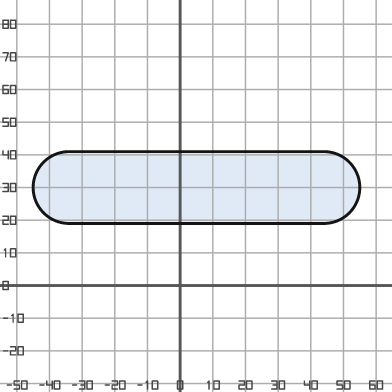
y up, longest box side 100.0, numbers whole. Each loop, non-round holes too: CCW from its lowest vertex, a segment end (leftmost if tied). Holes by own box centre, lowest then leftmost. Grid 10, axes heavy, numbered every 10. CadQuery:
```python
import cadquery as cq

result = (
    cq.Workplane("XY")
    .moveTo(-34.0, 19.0)
    .lineTo(44.0, 19.0)
    .threePointArc((55.0, 30.0), (44.0, 41.0))
    .lineTo(-34.0, 41.0)
    .threePointArc((-45.0, 30.0), (-34.0, 19.0))
    .close()
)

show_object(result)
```